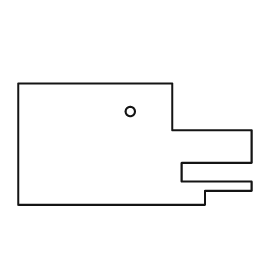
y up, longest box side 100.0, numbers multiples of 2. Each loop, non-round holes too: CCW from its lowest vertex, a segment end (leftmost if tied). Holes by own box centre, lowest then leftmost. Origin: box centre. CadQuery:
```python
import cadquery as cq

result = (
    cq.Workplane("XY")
    .moveTo(-50.0, -26.0)
    .lineTo(30.0, -26.0)
    .lineTo(30.0, -20.0)
    .lineTo(50.0, -20.0)
    .lineTo(50.0, -16.0)
    .lineTo(20.0, -16.0)
    .lineTo(20.0, -8.0)
    .lineTo(50.0, -8.0)
    .lineTo(50.0, 6.0)
    .lineTo(16.0, 6.0)
    .lineTo(16.0, 26.0)
    .lineTo(-50.0, 26.0)
    .close()
    .moveTo(-2.0, 14.0)
    .circle(2.0)
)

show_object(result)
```